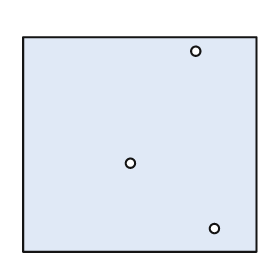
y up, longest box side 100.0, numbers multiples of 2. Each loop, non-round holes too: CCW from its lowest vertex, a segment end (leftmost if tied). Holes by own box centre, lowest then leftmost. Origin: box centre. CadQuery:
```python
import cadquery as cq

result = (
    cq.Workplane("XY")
    .moveTo(-50.0, -46.0)
    .lineTo(50.0, -46.0)
    .lineTo(50.0, 46.0)
    .lineTo(-50.0, 46.0)
    .close()
    .moveTo(32.0, -36.0)
    .circle(2.0)
    .moveTo(-4.0, -8.0)
    .circle(2.0)
    .moveTo(24.0, 40.0)
    .circle(2.0)
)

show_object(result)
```